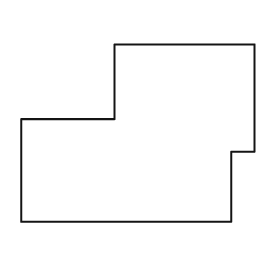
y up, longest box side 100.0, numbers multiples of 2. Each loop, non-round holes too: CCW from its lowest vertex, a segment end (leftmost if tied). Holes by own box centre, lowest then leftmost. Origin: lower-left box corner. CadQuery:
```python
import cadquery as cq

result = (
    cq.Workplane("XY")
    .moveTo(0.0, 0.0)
    .lineTo(90.0, 0.0)
    .lineTo(90.0, 30.0)
    .lineTo(100.0, 30.0)
    .lineTo(100.0, 76.0)
    .lineTo(40.0, 76.0)
    .lineTo(40.0, 44.0)
    .lineTo(0.0, 44.0)
    .close()
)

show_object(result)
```